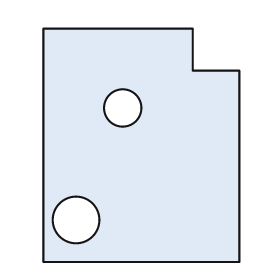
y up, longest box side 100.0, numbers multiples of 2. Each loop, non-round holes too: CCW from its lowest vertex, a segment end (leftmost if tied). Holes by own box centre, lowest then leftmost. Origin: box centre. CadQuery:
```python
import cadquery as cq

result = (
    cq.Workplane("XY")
    .moveTo(-42.0, -50.0)
    .lineTo(42.0, -50.0)
    .lineTo(42.0, 32.0)
    .lineTo(22.0, 32.0)
    .lineTo(22.0, 50.0)
    .lineTo(-42.0, 50.0)
    .close()
    .moveTo(-28.0, -32.0)
    .circle(10.0)
    .moveTo(-8.0, 16.0)
    .circle(8.0)
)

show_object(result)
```